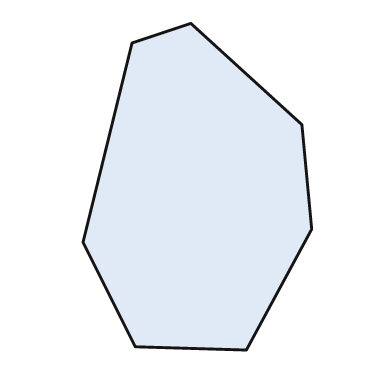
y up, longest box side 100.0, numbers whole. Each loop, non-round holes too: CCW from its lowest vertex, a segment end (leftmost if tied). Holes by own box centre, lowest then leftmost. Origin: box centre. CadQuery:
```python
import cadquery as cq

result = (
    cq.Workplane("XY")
    .moveTo(15.0, -50.0)
    .lineTo(35.0, -13.0)
    .lineTo(32.0, 19.0)
    .lineTo(-2.0, 50.0)
    .lineTo(-20.0, 44.0)
    .lineTo(-35.0, -17.0)
    .lineTo(-19.0, -49.0)
    .close()
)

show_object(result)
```